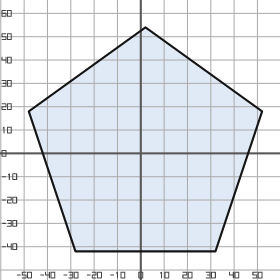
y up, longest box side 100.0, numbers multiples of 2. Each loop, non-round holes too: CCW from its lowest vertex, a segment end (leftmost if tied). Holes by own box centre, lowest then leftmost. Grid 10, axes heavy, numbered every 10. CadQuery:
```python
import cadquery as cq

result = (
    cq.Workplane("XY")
    .moveTo(-28.0, -42.0)
    .lineTo(32.0, -42.0)
    .lineTo(52.0, 18.0)
    .lineTo(2.0, 54.0)
    .lineTo(-48.0, 18.0)
    .close()
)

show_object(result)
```